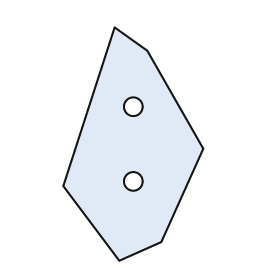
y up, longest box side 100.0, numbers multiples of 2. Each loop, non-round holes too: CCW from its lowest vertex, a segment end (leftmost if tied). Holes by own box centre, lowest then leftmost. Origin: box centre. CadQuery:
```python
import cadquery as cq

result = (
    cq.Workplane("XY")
    .moveTo(-6.0, -50.0)
    .lineTo(12.0, -42.0)
    .lineTo(30.0, -2.0)
    .lineTo(6.0, 40.0)
    .lineTo(-8.0, 50.0)
    .lineTo(-30.0, -18.0)
    .close()
    .moveTo(0.0, -16.0)
    .circle(4.0)
    .moveTo(0.0, 16.0)
    .circle(4.0)
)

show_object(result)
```